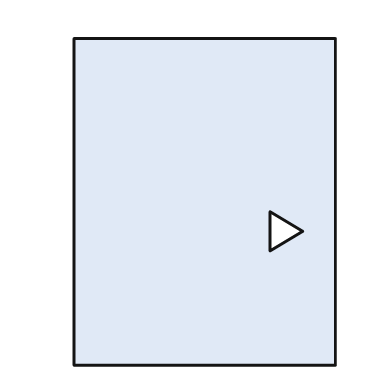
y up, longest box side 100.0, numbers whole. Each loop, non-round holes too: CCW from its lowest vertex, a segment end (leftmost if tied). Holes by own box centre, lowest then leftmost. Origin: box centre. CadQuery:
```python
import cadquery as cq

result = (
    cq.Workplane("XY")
    .moveTo(-40.0, -50.0)
    .lineTo(40.0, -50.0)
    .lineTo(40.0, 50.0)
    .lineTo(-40.0, 50.0)
    .close()
    .moveTo(20.0, -15.0)
    .lineTo(30.0, -9.0)
    .lineTo(20.0, -3.0)
    .close()
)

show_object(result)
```